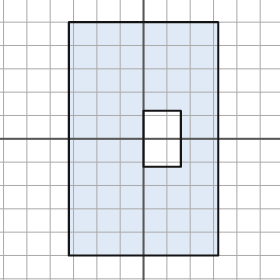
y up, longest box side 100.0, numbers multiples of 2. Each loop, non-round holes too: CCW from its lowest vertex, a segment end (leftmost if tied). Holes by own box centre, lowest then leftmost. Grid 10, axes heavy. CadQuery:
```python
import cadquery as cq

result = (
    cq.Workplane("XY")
    .moveTo(-32.0, -50.0)
    .lineTo(32.0, -50.0)
    .lineTo(32.0, 50.0)
    .lineTo(-32.0, 50.0)
    .close()
    .moveTo(0.0, -12.0)
    .lineTo(16.0, -12.0)
    .lineTo(16.0, 12.0)
    .lineTo(0.0, 12.0)
    .close()
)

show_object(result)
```